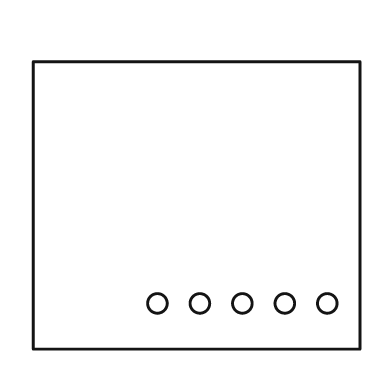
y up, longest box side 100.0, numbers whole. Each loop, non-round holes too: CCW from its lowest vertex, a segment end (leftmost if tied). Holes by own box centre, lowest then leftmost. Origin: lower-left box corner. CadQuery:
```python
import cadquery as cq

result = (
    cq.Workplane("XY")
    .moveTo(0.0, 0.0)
    .lineTo(100.0, 0.0)
    .lineTo(100.0, 88.0)
    .lineTo(0.0, 88.0)
    .close()
    .moveTo(38.0, 14.0)
    .circle(3.0)
    .moveTo(51.0, 14.0)
    .circle(3.0)
    .moveTo(64.0, 14.0)
    .circle(3.0)
    .moveTo(77.0, 14.0)
    .circle(3.0)
    .moveTo(90.0, 14.0)
    .circle(3.0)
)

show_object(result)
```